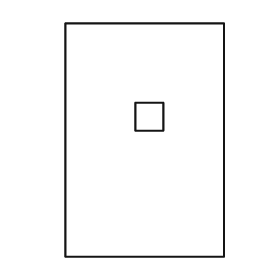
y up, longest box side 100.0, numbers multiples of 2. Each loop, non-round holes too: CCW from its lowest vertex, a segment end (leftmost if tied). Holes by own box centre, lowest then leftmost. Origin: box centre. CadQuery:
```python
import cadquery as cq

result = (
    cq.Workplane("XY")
    .moveTo(-34.0, -50.0)
    .lineTo(34.0, -50.0)
    .lineTo(34.0, 50.0)
    .lineTo(-34.0, 50.0)
    .close()
    .moveTo(-4.0, 4.0)
    .lineTo(8.0, 4.0)
    .lineTo(8.0, 16.0)
    .lineTo(-4.0, 16.0)
    .close()
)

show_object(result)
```